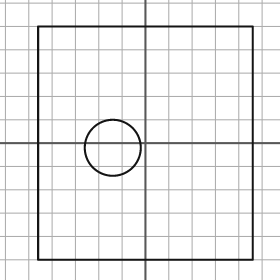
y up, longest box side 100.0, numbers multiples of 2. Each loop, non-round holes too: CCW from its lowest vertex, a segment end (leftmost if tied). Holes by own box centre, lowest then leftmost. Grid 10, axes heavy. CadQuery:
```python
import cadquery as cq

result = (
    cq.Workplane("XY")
    .moveTo(-46.0, -50.0)
    .lineTo(46.0, -50.0)
    .lineTo(46.0, 50.0)
    .lineTo(-46.0, 50.0)
    .close()
    .moveTo(-14.0, -2.0)
    .circle(12.0)
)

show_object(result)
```